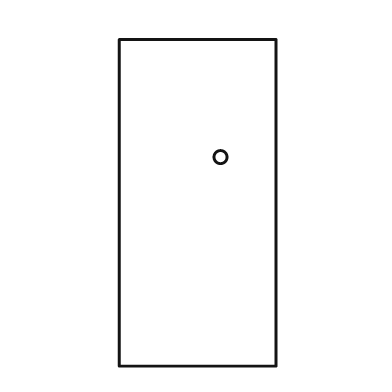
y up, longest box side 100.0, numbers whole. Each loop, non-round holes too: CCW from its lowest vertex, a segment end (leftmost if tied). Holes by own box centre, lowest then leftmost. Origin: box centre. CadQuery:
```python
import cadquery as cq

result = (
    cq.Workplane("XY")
    .moveTo(-24.0, -50.0)
    .lineTo(24.0, -50.0)
    .lineTo(24.0, 50.0)
    .lineTo(-24.0, 50.0)
    .close()
    .moveTo(7.0, 14.0)
    .circle(2.0)
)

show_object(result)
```